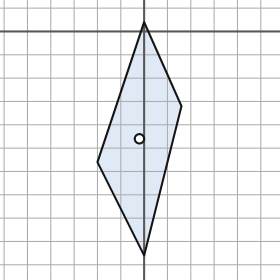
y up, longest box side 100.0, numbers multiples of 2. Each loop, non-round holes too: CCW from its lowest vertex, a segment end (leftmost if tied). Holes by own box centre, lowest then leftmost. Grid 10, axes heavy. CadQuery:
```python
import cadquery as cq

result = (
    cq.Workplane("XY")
    .moveTo(0.0, -96.0)
    .lineTo(16.0, -32.0)
    .lineTo(0.0, 4.0)
    .lineTo(-20.0, -56.0)
    .close()
    .moveTo(-2.0, -46.0)
    .circle(2.0)
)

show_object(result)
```